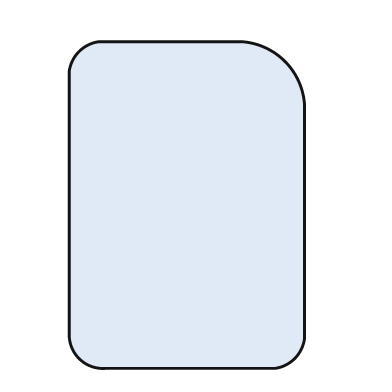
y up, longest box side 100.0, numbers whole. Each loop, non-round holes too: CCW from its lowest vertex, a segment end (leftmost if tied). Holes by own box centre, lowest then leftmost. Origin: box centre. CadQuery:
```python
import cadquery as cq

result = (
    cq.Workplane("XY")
    .moveTo(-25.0, -50.0)
    .lineTo(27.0, -50.0)
    .threePointArc((33.0, -47.0), (36.0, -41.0))
    .lineTo(36.0, 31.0)
    .threePointArc((30.0, 44.0), (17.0, 50.0))
    .lineTo(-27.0, 50.0)
    .threePointArc((-33.0, 47.0), (-36.0, 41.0))
    .lineTo(-36.0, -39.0)
    .threePointArc((-33.0, -47.0), (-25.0, -50.0))
    .close()
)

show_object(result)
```